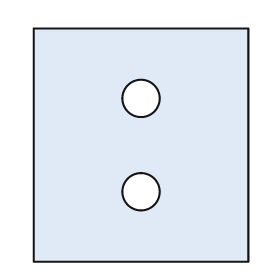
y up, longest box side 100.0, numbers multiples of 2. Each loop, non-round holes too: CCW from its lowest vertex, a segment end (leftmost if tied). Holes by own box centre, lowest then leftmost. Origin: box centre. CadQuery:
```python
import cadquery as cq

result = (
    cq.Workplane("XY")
    .moveTo(-46.0, -50.0)
    .lineTo(46.0, -50.0)
    .lineTo(46.0, 50.0)
    .lineTo(-46.0, 50.0)
    .close()
    .moveTo(0.0, -20.0)
    .circle(8.0)
    .moveTo(0.0, 20.0)
    .circle(8.0)
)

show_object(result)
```